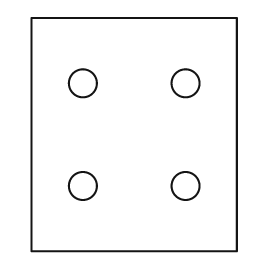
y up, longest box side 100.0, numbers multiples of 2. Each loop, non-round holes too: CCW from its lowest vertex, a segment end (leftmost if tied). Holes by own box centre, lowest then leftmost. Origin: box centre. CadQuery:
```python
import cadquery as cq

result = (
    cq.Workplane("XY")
    .moveTo(-44.0, -50.0)
    .lineTo(44.0, -50.0)
    .lineTo(44.0, 50.0)
    .lineTo(-44.0, 50.0)
    .close()
    .moveTo(-22.0, -22.0)
    .circle(6.0)
    .moveTo(22.0, -22.0)
    .circle(6.0)
    .moveTo(-22.0, 22.0)
    .circle(6.0)
    .moveTo(22.0, 22.0)
    .circle(6.0)
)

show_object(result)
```